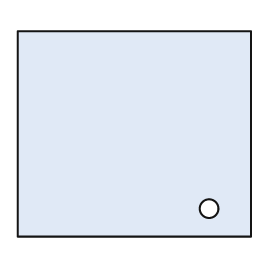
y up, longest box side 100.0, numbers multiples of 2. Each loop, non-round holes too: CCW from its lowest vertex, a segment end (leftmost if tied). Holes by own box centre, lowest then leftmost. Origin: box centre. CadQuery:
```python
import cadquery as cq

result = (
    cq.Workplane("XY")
    .moveTo(-50.0, -44.0)
    .lineTo(50.0, -44.0)
    .lineTo(50.0, 44.0)
    .lineTo(-50.0, 44.0)
    .close()
    .moveTo(32.0, -32.0)
    .circle(4.0)
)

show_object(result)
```